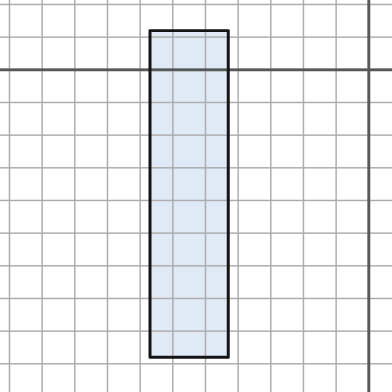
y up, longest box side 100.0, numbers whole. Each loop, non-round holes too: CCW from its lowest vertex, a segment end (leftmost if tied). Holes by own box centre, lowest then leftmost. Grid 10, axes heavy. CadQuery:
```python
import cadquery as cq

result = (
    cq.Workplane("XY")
    .moveTo(-67.0, -88.0)
    .lineTo(-43.0, -88.0)
    .lineTo(-43.0, 12.0)
    .lineTo(-67.0, 12.0)
    .close()
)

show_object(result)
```